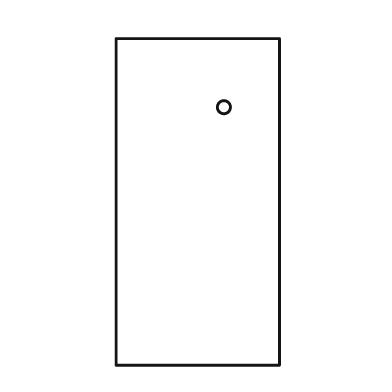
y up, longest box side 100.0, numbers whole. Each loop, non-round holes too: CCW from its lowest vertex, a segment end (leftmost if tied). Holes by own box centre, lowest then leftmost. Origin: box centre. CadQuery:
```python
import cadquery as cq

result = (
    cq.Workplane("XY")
    .moveTo(-25.0, -50.0)
    .lineTo(25.0, -50.0)
    .lineTo(25.0, 50.0)
    .lineTo(-25.0, 50.0)
    .close()
    .moveTo(8.0, 29.0)
    .circle(2.0)
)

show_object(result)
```